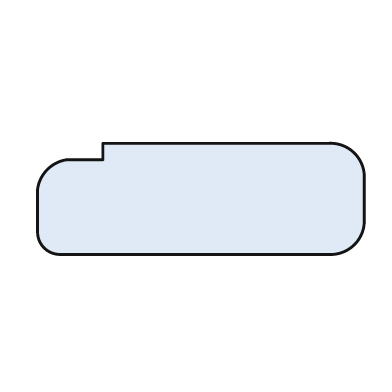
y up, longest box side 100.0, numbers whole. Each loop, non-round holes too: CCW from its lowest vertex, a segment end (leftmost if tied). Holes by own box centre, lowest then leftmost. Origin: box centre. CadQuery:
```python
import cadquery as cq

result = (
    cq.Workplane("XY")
    .moveTo(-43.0, -17.0)
    .lineTo(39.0, -17.0)
    .threePointArc((47.0, -14.0), (50.0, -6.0))
    .lineTo(50.0, 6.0)
    .threePointArc((47.0, 14.0), (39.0, 17.0))
    .lineTo(-30.0, 17.0)
    .lineTo(-30.0, 12.0)
    .lineTo(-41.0, 12.0)
    .threePointArc((-47.0, 9.0), (-50.0, 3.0))
    .lineTo(-50.0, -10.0)
    .threePointArc((-48.0, -15.0), (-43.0, -17.0))
    .close()
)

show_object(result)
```